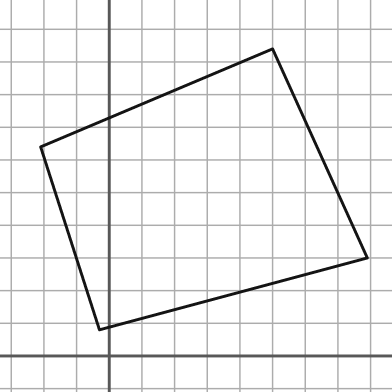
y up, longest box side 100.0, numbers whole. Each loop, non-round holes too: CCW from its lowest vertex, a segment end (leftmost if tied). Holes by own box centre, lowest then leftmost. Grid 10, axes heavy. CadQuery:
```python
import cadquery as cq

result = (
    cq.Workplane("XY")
    .moveTo(-3.0, 8.0)
    .lineTo(79.0, 30.0)
    .lineTo(50.0, 94.0)
    .lineTo(-21.0, 64.0)
    .close()
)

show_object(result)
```